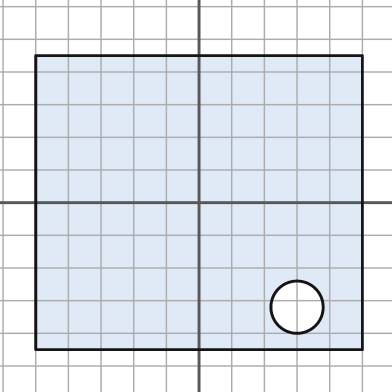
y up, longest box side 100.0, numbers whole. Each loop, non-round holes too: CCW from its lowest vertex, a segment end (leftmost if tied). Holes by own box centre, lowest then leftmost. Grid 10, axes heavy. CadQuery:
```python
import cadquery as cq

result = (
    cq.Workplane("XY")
    .moveTo(-50.0, -45.0)
    .lineTo(50.0, -45.0)
    .lineTo(50.0, 45.0)
    .lineTo(-50.0, 45.0)
    .close()
    .moveTo(30.0, -32.0)
    .circle(8.0)
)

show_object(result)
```